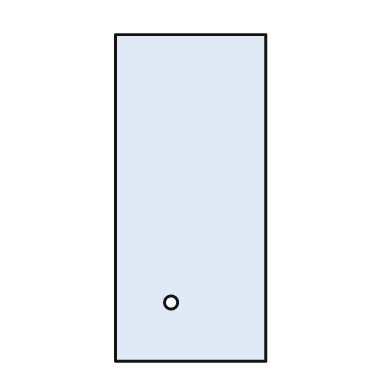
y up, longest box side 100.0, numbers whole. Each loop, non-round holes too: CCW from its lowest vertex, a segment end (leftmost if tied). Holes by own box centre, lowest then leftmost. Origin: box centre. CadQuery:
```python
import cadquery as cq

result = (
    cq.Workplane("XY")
    .moveTo(-23.0, -50.0)
    .lineTo(23.0, -50.0)
    .lineTo(23.0, 50.0)
    .lineTo(-23.0, 50.0)
    .close()
    .moveTo(-6.0, -32.0)
    .circle(2.0)
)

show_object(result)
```